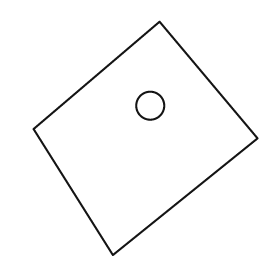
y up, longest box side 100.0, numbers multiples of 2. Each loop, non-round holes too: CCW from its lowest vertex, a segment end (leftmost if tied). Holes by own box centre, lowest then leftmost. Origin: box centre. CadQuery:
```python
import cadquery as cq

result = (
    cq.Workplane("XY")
    .moveTo(-14.0, -50.0)
    .lineTo(48.0, 0.0)
    .lineTo(6.0, 50.0)
    .lineTo(-48.0, 4.0)
    .close()
    .moveTo(2.0, 14.0)
    .circle(6.0)
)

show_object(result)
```